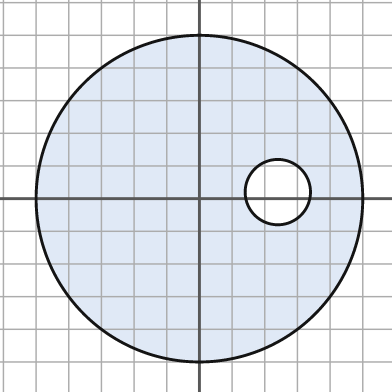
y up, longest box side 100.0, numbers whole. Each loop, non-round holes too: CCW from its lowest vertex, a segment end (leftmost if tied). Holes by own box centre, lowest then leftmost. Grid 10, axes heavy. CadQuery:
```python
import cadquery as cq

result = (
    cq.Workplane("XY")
    .moveTo(0.0, 0.0)
    .circle(50.0)
    .moveTo(24.0, 2.0)
    .circle(10.0)
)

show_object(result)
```